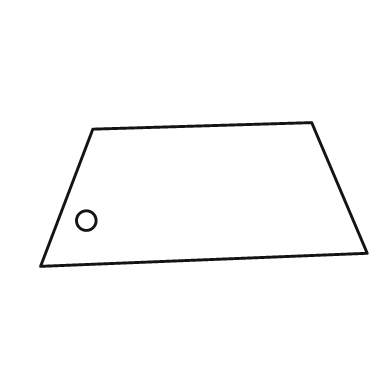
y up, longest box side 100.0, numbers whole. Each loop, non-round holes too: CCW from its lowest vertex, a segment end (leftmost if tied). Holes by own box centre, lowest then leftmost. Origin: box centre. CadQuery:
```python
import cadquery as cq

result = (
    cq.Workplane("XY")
    .moveTo(-50.0, -22.0)
    .lineTo(50.0, -18.0)
    .lineTo(33.0, 22.0)
    .lineTo(-34.0, 20.0)
    .close()
    .moveTo(-36.0, -8.0)
    .circle(3.0)
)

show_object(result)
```